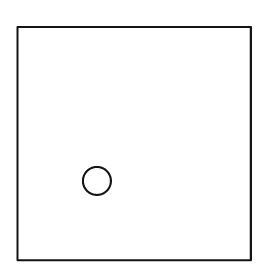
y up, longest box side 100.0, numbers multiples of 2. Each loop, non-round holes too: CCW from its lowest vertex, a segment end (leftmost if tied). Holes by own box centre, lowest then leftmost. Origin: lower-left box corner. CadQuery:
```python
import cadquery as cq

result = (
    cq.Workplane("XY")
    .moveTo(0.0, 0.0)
    .lineTo(100.0, 0.0)
    .lineTo(100.0, 100.0)
    .lineTo(0.0, 100.0)
    .close()
    .moveTo(34.0, 34.0)
    .circle(6.0)
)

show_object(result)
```